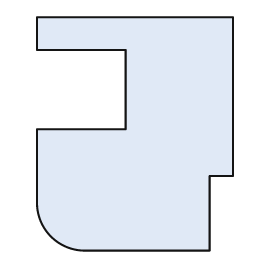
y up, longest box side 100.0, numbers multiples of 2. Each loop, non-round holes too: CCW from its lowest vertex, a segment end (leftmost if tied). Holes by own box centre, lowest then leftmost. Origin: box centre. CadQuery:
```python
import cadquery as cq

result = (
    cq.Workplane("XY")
    .moveTo(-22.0, -50.0)
    .lineTo(32.0, -50.0)
    .lineTo(32.0, -18.0)
    .lineTo(42.0, -18.0)
    .lineTo(42.0, 50.0)
    .lineTo(-42.0, 50.0)
    .lineTo(-42.0, 36.0)
    .lineTo(-4.0, 36.0)
    .lineTo(-4.0, 2.0)
    .lineTo(-42.0, 2.0)
    .lineTo(-42.0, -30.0)
    .threePointArc((-36.0, -44.0), (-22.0, -50.0))
    .close()
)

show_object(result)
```